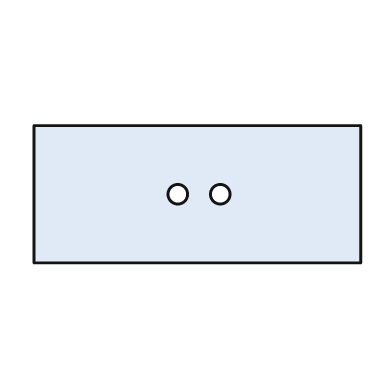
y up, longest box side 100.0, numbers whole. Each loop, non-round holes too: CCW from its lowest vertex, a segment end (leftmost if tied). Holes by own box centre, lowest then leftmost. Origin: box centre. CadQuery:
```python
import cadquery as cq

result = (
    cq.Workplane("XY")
    .moveTo(-50.0, -21.0)
    .lineTo(50.0, -21.0)
    .lineTo(50.0, 21.0)
    .lineTo(-50.0, 21.0)
    .close()
    .moveTo(-6.0, 0.0)
    .circle(3.0)
    .moveTo(7.0, 0.0)
    .circle(3.0)
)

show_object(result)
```